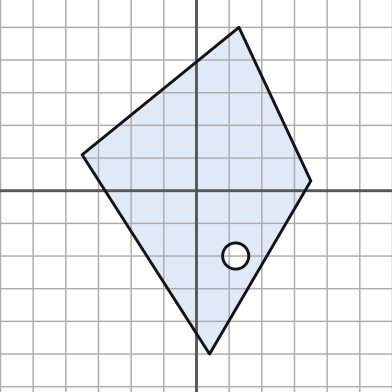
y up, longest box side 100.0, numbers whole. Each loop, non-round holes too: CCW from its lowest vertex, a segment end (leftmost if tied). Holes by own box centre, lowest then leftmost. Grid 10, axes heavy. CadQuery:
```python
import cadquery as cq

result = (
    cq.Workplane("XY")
    .moveTo(4.0, -50.0)
    .lineTo(35.0, 3.0)
    .lineTo(13.0, 50.0)
    .lineTo(-35.0, 11.0)
    .close()
    .moveTo(12.0, -20.0)
    .circle(4.0)
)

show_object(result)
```